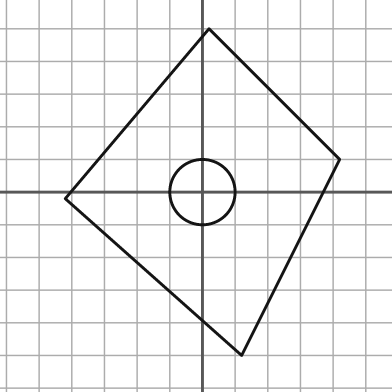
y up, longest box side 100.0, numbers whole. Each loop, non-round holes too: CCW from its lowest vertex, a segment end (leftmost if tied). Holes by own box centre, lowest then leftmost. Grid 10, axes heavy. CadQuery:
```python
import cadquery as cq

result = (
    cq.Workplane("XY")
    .moveTo(12.0, -50.0)
    .lineTo(42.0, 10.0)
    .lineTo(2.0, 50.0)
    .lineTo(-42.0, -2.0)
    .close()
    .moveTo(0.0, 0.0)
    .circle(10.0)
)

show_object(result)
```